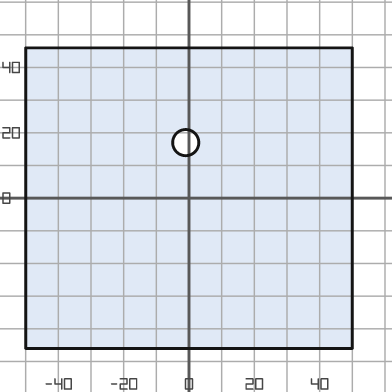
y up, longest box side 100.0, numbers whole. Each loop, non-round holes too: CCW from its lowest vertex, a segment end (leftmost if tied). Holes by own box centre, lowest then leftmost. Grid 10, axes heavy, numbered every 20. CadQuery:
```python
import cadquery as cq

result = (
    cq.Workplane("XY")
    .moveTo(-50.0, -46.0)
    .lineTo(50.0, -46.0)
    .lineTo(50.0, 46.0)
    .lineTo(-50.0, 46.0)
    .close()
    .moveTo(-1.0, 17.0)
    .circle(4.0)
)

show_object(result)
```